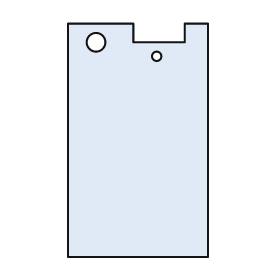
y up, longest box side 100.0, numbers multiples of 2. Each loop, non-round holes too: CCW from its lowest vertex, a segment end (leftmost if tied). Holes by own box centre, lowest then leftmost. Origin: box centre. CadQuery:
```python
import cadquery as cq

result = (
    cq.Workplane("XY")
    .moveTo(-30.0, -50.0)
    .lineTo(30.0, -50.0)
    .lineTo(30.0, 50.0)
    .lineTo(20.0, 50.0)
    .lineTo(20.0, 42.0)
    .lineTo(-2.0, 42.0)
    .lineTo(-2.0, 50.0)
    .lineTo(-30.0, 50.0)
    .close()
    .moveTo(8.0, 36.0)
    .circle(2.0)
    .moveTo(-18.0, 42.0)
    .circle(4.0)
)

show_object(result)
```